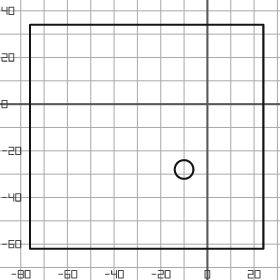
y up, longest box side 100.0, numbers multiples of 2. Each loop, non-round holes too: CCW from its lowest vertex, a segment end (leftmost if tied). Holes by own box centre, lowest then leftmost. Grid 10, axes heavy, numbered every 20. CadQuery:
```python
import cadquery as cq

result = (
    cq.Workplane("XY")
    .moveTo(-76.0, -62.0)
    .lineTo(24.0, -62.0)
    .lineTo(24.0, 34.0)
    .lineTo(-76.0, 34.0)
    .close()
    .moveTo(-10.0, -28.0)
    .circle(4.0)
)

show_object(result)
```